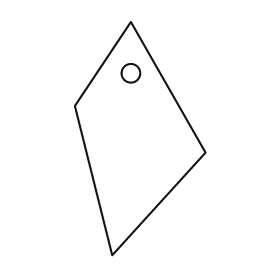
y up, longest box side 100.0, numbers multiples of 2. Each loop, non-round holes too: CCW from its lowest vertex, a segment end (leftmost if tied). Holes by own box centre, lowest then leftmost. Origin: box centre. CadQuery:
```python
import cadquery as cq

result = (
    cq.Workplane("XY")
    .moveTo(-12.0, -50.0)
    .lineTo(28.0, -6.0)
    .lineTo(-4.0, 50.0)
    .lineTo(-28.0, 14.0)
    .close()
    .moveTo(-4.0, 28.0)
    .circle(4.0)
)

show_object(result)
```